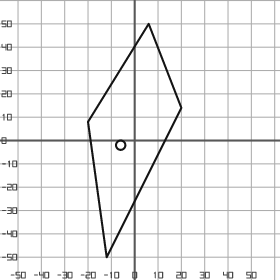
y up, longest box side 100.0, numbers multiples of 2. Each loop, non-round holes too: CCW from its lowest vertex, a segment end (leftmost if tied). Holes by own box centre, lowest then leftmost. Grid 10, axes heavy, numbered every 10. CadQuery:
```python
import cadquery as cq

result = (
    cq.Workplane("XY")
    .moveTo(-12.0, -50.0)
    .lineTo(20.0, 14.0)
    .lineTo(6.0, 50.0)
    .lineTo(-20.0, 8.0)
    .close()
    .moveTo(-6.0, -2.0)
    .circle(2.0)
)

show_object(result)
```